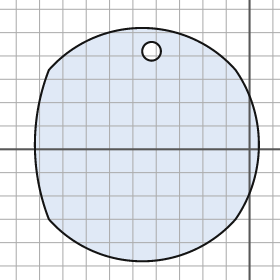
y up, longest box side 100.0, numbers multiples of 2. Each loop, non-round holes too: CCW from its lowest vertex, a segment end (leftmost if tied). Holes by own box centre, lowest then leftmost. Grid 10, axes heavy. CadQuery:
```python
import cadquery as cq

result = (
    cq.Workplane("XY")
    .moveTo(-86.0, -30.0)
    .threePointArc((-46.0, -48.0), (-6.0, -30.0))
    .threePointArc((4.0, 2.0), (-6.0, 34.0))
    .threePointArc((-46.0, 52.0), (-86.0, 34.0))
    .threePointArc((-92.0, 2.0), (-86.0, -30.0))
    .close()
    .moveTo(-42.0, 42.0)
    .circle(4.0)
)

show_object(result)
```